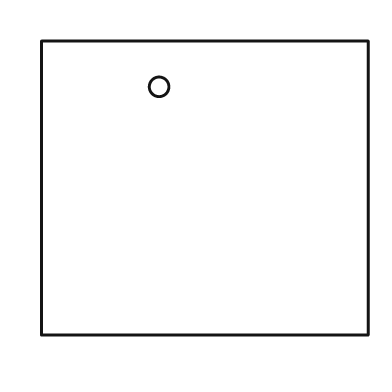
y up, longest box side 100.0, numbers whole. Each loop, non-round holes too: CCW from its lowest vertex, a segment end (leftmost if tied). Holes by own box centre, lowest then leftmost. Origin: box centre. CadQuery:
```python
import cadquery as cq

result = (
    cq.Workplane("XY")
    .moveTo(-50.0, -45.0)
    .lineTo(50.0, -45.0)
    .lineTo(50.0, 45.0)
    .lineTo(-50.0, 45.0)
    .close()
    .moveTo(-14.0, 31.0)
    .circle(3.0)
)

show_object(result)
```